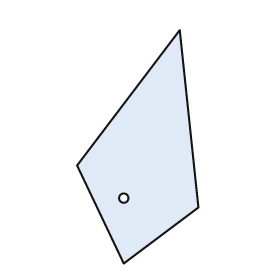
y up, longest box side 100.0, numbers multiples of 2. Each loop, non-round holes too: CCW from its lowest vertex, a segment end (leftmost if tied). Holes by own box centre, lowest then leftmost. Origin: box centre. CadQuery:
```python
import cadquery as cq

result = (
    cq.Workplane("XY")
    .moveTo(-6.0, -50.0)
    .lineTo(26.0, -26.0)
    .lineTo(18.0, 50.0)
    .lineTo(-26.0, -8.0)
    .close()
    .moveTo(-6.0, -22.0)
    .circle(2.0)
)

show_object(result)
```